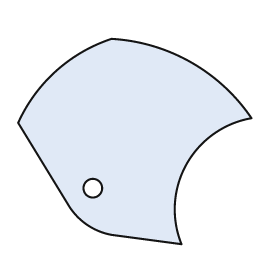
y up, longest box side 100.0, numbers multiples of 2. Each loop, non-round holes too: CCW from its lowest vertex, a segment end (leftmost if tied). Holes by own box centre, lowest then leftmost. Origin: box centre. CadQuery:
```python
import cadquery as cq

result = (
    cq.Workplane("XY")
    .moveTo(20.0, -44.0)
    .threePointArc((22.0, -10.0), (50.0, 10.0))
    .threePointArc((24.0, 34.0), (-10.0, 44.0))
    .threePointArc((-34.0, 30.0), (-50.0, 8.0))
    .lineTo(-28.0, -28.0)
    .threePointArc((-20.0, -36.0), (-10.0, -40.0))
    .close()
    .moveTo(-18.0, -20.0)
    .circle(4.0)
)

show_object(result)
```